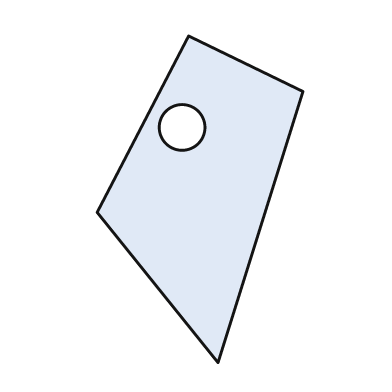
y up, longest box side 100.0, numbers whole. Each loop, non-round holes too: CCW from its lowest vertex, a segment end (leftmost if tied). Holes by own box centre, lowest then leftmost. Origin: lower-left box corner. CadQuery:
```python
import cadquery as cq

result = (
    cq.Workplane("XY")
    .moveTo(37.0, 0.0)
    .lineTo(63.0, 83.0)
    .lineTo(28.0, 100.0)
    .lineTo(0.0, 46.0)
    .close()
    .moveTo(26.0, 72.0)
    .circle(7.0)
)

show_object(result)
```